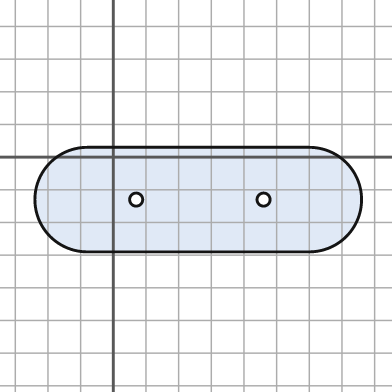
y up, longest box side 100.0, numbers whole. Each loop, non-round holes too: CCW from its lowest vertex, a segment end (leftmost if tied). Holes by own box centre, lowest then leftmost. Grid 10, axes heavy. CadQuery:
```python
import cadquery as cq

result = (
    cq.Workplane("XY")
    .moveTo(-8.0, -29.0)
    .lineTo(60.0, -29.0)
    .threePointArc((76.0, -13.0), (60.0, 3.0))
    .lineTo(-8.0, 3.0)
    .threePointArc((-24.0, -13.0), (-8.0, -29.0))
    .close()
    .moveTo(7.0, -13.0)
    .circle(2.0)
    .moveTo(46.0, -13.0)
    .circle(2.0)
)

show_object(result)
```